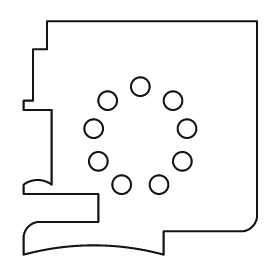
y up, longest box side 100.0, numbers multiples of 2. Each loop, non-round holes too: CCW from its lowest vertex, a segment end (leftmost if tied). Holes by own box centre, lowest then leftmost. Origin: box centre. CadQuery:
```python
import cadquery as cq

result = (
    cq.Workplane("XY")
    .moveTo(-50.0, -50.0)
    .threePointArc((-20.0, -46.0), (10.0, -50.0))
    .lineTo(10.0, -40.0)
    .lineTo(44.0, -40.0)
    .threePointArc((48.0, -38.0), (50.0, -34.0))
    .lineTo(50.0, 50.0)
    .lineTo(-40.0, 50.0)
    .lineTo(-40.0, 38.0)
    .lineTo(-46.0, 38.0)
    .lineTo(-46.0, 16.0)
    .lineTo(-50.0, 16.0)
    .lineTo(-50.0, 12.0)
    .lineTo(-38.0, 12.0)
    .lineTo(-38.0, -20.0)
    .threePointArc((-44.0, -18.0), (-50.0, -20.0))
    .lineTo(-50.0, -24.0)
    .lineTo(-18.0, -24.0)
    .lineTo(-18.0, -36.0)
    .lineTo(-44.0, -36.0)
    .threePointArc((-48.0, -38.0), (-50.0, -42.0))
    .close()
    .moveTo(-8.0, -20.0)
    .circle(4.0)
    .moveTo(8.0, -20.0)
    .circle(4.0)
    .moveTo(-18.0, -10.0)
    .circle(4.0)
    .moveTo(18.0, -10.0)
    .circle(4.0)
    .moveTo(-20.0, 4.0)
    .circle(4.0)
    .moveTo(20.0, 4.0)
    .circle(4.0)
    .moveTo(-14.0, 16.0)
    .circle(4.0)
    .moveTo(14.0, 16.0)
    .circle(4.0)
    .moveTo(0.0, 22.0)
    .circle(4.0)
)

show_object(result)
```